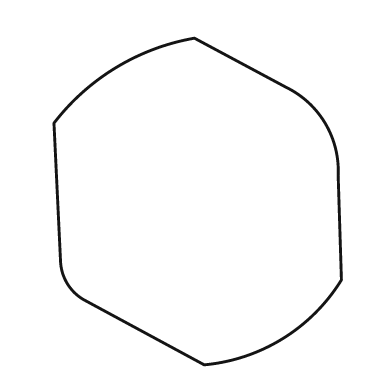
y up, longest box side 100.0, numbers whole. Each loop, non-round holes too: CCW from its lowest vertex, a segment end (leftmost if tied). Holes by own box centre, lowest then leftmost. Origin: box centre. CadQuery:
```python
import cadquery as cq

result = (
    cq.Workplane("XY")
    .moveTo(2.0, -50.0)
    .threePointArc((26.0, -42.0), (44.0, -24.0))
    .lineTo(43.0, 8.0)
    .threePointArc((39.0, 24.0), (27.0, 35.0))
    .lineTo(-1.0, 50.0)
    .threePointArc((-25.0, 41.0), (-44.0, 24.0))
    .lineTo(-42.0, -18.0)
    .threePointArc((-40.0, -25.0), (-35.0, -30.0))
    .close()
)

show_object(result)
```